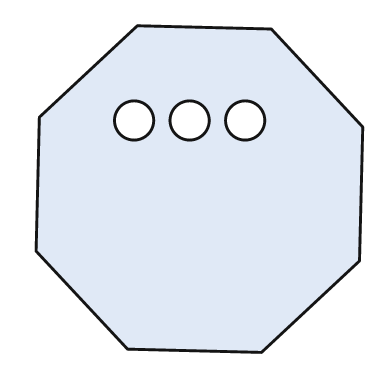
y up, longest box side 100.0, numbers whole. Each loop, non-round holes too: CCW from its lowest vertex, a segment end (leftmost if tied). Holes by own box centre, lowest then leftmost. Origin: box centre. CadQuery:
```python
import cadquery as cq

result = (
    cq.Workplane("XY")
    .moveTo(19.0, -50.0)
    .lineTo(49.0, -22.0)
    .lineTo(50.0, 19.0)
    .lineTo(22.0, 49.0)
    .lineTo(-19.0, 50.0)
    .lineTo(-49.0, 22.0)
    .lineTo(-50.0, -19.0)
    .lineTo(-22.0, -49.0)
    .close()
    .moveTo(-20.0, 21.0)
    .circle(6.0)
    .moveTo(-3.0, 21.0)
    .circle(6.0)
    .moveTo(14.0, 21.0)
    .circle(6.0)
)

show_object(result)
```